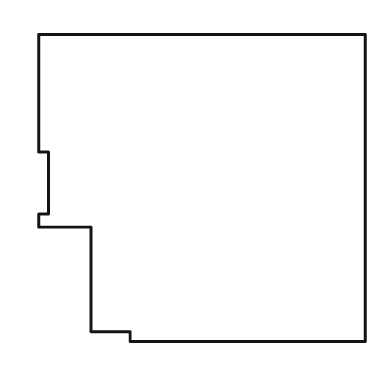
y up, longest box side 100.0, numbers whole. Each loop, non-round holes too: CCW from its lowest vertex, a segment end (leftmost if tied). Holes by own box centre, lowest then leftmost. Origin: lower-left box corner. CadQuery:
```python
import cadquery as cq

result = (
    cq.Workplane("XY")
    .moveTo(28.0, 0.0)
    .lineTo(100.0, 0.0)
    .lineTo(100.0, 94.0)
    .lineTo(0.0, 94.0)
    .lineTo(0.0, 58.0)
    .lineTo(3.0, 58.0)
    .lineTo(3.0, 39.0)
    .lineTo(0.0, 39.0)
    .lineTo(0.0, 35.0)
    .lineTo(16.0, 35.0)
    .lineTo(16.0, 3.0)
    .lineTo(28.0, 3.0)
    .close()
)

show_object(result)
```